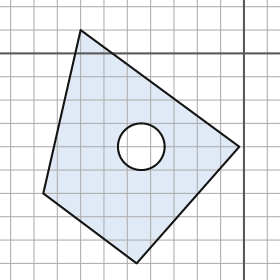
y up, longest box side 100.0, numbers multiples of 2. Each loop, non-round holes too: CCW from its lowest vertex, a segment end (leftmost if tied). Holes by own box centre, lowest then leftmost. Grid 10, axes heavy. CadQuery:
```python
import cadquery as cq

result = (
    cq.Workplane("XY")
    .moveTo(-46.0, -90.0)
    .lineTo(-2.0, -40.0)
    .lineTo(-70.0, 10.0)
    .lineTo(-86.0, -60.0)
    .close()
    .moveTo(-44.0, -40.0)
    .circle(10.0)
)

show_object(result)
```